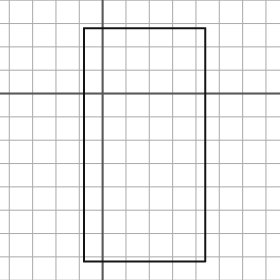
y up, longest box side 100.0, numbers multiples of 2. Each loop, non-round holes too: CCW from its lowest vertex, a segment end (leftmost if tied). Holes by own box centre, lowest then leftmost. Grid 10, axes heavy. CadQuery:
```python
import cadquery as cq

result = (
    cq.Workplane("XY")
    .moveTo(-8.0, -72.0)
    .lineTo(44.0, -72.0)
    .lineTo(44.0, 28.0)
    .lineTo(-8.0, 28.0)
    .close()
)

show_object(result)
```